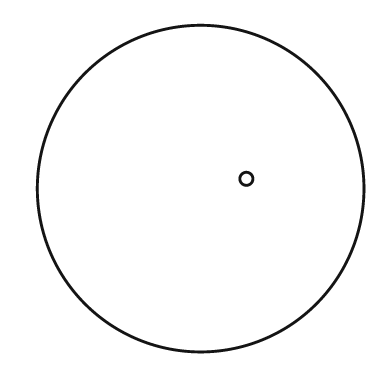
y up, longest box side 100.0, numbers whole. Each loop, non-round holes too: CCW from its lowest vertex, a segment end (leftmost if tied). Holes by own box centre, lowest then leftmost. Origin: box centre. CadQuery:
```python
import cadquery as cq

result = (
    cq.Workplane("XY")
    .moveTo(0.0, 0.0)
    .circle(50.0)
    .moveTo(14.0, 3.0)
    .circle(2.0)
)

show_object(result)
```